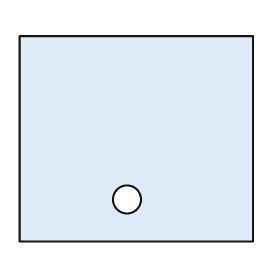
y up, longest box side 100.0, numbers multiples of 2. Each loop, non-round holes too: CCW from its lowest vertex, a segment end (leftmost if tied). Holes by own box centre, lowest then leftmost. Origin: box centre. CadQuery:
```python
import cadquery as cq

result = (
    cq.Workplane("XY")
    .moveTo(-50.0, -44.0)
    .lineTo(50.0, -44.0)
    .lineTo(50.0, 44.0)
    .lineTo(-50.0, 44.0)
    .close()
    .moveTo(-4.0, -26.0)
    .circle(6.0)
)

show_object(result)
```